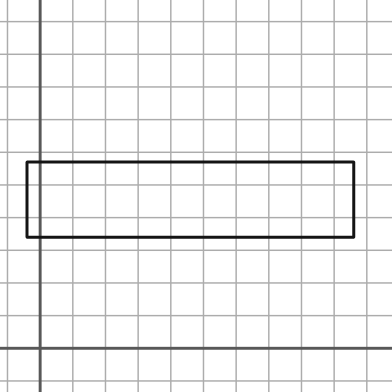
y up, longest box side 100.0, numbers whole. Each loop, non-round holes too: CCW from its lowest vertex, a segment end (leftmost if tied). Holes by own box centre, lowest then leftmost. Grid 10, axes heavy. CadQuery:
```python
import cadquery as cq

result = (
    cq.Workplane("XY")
    .moveTo(-4.0, 34.0)
    .lineTo(96.0, 34.0)
    .lineTo(96.0, 57.0)
    .lineTo(-4.0, 57.0)
    .close()
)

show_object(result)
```